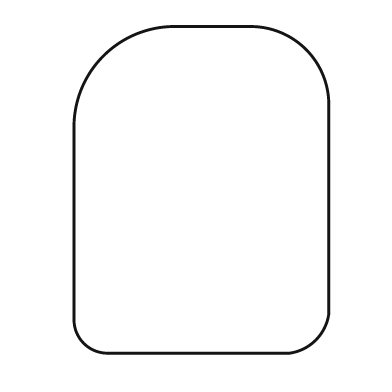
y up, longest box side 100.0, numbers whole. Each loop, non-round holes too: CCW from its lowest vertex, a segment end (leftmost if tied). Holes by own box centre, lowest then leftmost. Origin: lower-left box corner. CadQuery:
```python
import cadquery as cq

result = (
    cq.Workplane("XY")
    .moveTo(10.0, 0.0)
    .lineTo(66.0, 0.0)
    .threePointArc((74.0, 4.0), (78.0, 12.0))
    .lineTo(78.0, 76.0)
    .threePointArc((71.0, 93.0), (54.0, 100.0))
    .lineTo(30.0, 100.0)
    .threePointArc((9.0, 91.0), (0.0, 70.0))
    .lineTo(0.0, 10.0)
    .threePointArc((3.0, 3.0), (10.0, 0.0))
    .close()
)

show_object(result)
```